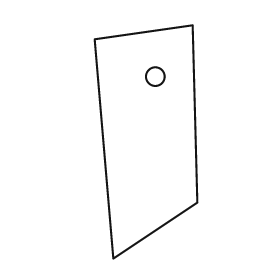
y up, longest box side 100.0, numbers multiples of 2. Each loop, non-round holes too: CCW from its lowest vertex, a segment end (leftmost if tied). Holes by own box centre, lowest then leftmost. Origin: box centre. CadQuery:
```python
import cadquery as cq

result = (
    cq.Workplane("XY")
    .moveTo(-14.0, -50.0)
    .lineTo(22.0, -26.0)
    .lineTo(20.0, 50.0)
    .lineTo(-22.0, 44.0)
    .close()
    .moveTo(4.0, 28.0)
    .circle(4.0)
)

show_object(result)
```